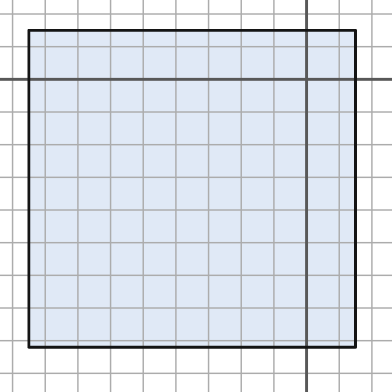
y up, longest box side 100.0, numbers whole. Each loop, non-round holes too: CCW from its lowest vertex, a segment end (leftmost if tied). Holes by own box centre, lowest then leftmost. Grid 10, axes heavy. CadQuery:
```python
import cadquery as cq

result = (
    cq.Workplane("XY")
    .moveTo(-85.0, -82.0)
    .lineTo(15.0, -82.0)
    .lineTo(15.0, 15.0)
    .lineTo(-85.0, 15.0)
    .close()
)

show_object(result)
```